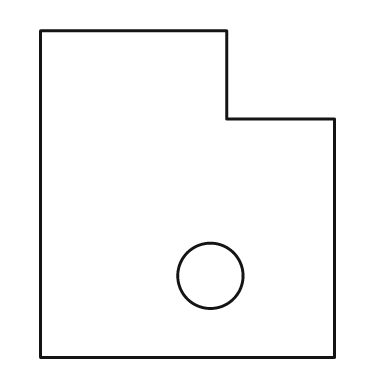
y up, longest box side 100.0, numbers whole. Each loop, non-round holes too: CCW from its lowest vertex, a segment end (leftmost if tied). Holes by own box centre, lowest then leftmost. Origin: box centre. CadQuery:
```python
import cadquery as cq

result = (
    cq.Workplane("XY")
    .moveTo(-45.0, -50.0)
    .lineTo(45.0, -50.0)
    .lineTo(45.0, 23.0)
    .lineTo(12.0, 23.0)
    .lineTo(12.0, 50.0)
    .lineTo(-45.0, 50.0)
    .close()
    .moveTo(7.0, -25.0)
    .circle(10.0)
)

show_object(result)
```